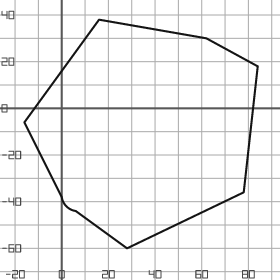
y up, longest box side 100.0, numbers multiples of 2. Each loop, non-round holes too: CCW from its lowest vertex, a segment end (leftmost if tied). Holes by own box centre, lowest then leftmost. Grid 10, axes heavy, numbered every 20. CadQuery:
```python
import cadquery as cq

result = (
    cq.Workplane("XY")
    .moveTo(28.0, -60.0)
    .lineTo(78.0, -36.0)
    .lineTo(84.0, 18.0)
    .lineTo(62.0, 30.0)
    .lineTo(16.0, 38.0)
    .lineTo(-16.0, -6.0)
    .lineTo(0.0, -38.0)
    .threePointArc((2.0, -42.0), (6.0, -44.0))
    .close()
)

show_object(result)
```